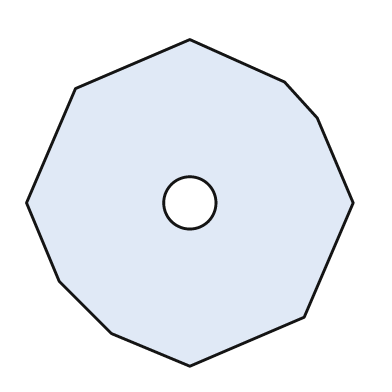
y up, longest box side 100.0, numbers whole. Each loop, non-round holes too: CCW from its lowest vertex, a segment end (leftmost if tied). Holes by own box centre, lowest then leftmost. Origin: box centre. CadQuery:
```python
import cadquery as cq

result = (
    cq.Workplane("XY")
    .moveTo(0.0, -50.0)
    .lineTo(35.0, -35.0)
    .lineTo(50.0, 0.0)
    .lineTo(39.0, 26.0)
    .lineTo(29.0, 37.0)
    .lineTo(0.0, 50.0)
    .lineTo(-35.0, 35.0)
    .lineTo(-50.0, 0.0)
    .lineTo(-40.0, -24.0)
    .lineTo(-24.0, -40.0)
    .close()
    .moveTo(0.0, 0.0)
    .circle(8.0)
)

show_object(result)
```